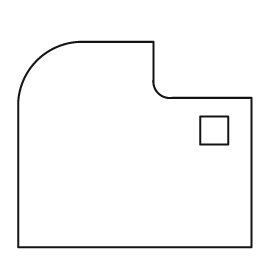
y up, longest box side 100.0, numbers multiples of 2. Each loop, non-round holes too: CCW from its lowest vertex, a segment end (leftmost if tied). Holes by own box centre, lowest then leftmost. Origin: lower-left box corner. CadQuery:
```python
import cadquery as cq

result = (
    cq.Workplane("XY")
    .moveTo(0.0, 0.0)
    .lineTo(100.0, 0.0)
    .lineTo(100.0, 64.0)
    .lineTo(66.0, 64.0)
    .threePointArc((60.0, 66.0), (58.0, 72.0))
    .lineTo(58.0, 88.0)
    .lineTo(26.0, 88.0)
    .threePointArc((8.0, 80.0), (0.0, 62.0))
    .close()
    .moveTo(78.0, 44.0)
    .lineTo(90.0, 44.0)
    .lineTo(90.0, 56.0)
    .lineTo(78.0, 56.0)
    .close()
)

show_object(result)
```